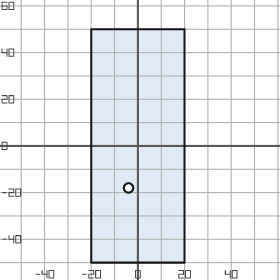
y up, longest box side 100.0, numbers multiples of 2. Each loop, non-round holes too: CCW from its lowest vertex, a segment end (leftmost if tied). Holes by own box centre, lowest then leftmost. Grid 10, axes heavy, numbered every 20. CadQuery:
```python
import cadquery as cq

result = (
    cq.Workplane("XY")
    .moveTo(-20.0, -50.0)
    .lineTo(20.0, -50.0)
    .lineTo(20.0, 50.0)
    .lineTo(-20.0, 50.0)
    .close()
    .moveTo(-4.0, -18.0)
    .circle(2.0)
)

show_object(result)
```